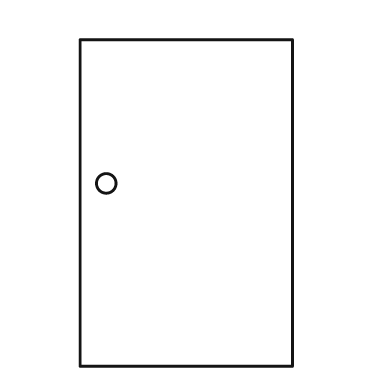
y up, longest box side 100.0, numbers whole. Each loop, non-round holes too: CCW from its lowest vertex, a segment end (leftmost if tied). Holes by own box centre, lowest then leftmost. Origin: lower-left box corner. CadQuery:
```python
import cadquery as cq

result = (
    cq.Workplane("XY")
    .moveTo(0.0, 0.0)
    .lineTo(65.0, 0.0)
    .lineTo(65.0, 100.0)
    .lineTo(0.0, 100.0)
    .close()
    .moveTo(8.0, 56.0)
    .circle(3.0)
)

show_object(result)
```